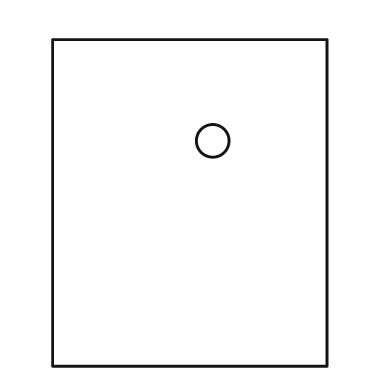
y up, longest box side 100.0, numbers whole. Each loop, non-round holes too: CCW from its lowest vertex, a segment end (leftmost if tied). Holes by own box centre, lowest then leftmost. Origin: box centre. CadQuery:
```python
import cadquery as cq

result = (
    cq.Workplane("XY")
    .moveTo(-42.0, -50.0)
    .lineTo(42.0, -50.0)
    .lineTo(42.0, 50.0)
    .lineTo(-42.0, 50.0)
    .close()
    .moveTo(7.0, 19.0)
    .circle(5.0)
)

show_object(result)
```